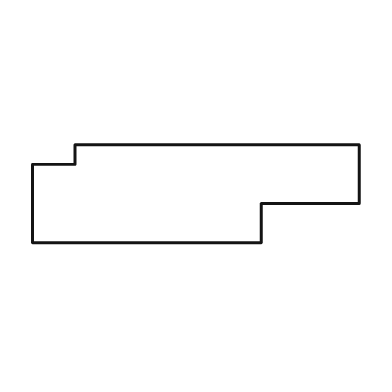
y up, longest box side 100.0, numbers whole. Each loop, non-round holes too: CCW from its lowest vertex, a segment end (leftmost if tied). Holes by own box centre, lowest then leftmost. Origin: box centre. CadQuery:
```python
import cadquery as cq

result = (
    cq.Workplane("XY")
    .moveTo(-50.0, -15.0)
    .lineTo(20.0, -15.0)
    .lineTo(20.0, -3.0)
    .lineTo(50.0, -3.0)
    .lineTo(50.0, 15.0)
    .lineTo(-37.0, 15.0)
    .lineTo(-37.0, 9.0)
    .lineTo(-50.0, 9.0)
    .close()
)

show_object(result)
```